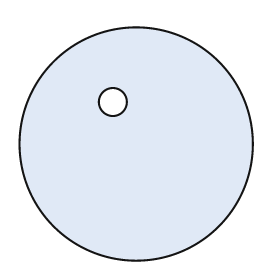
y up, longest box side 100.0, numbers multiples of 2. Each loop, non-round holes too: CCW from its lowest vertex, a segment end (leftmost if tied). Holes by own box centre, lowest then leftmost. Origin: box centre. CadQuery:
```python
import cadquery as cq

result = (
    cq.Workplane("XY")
    .moveTo(0.0, 0.0)
    .circle(50.0)
    .moveTo(-10.0, 18.0)
    .circle(6.0)
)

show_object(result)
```